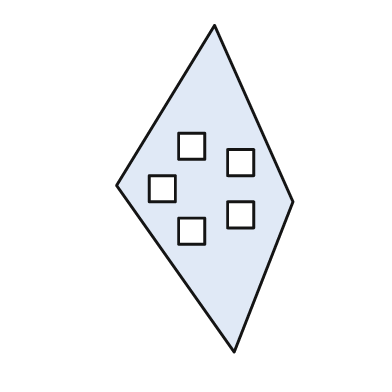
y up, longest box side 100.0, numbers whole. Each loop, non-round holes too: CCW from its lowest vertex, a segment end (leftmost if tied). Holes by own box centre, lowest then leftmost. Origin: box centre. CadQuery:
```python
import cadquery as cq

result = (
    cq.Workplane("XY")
    .moveTo(9.0, -50.0)
    .lineTo(27.0, -4.0)
    .lineTo(3.0, 50.0)
    .lineTo(-27.0, 1.0)
    .close()
    .moveTo(-8.0, -17.0)
    .lineTo(0.0, -17.0)
    .lineTo(0.0, -9.0)
    .lineTo(-8.0, -9.0)
    .close()
    .moveTo(7.0, -12.0)
    .lineTo(15.0, -12.0)
    .lineTo(15.0, -4.0)
    .lineTo(7.0, -4.0)
    .close()
    .moveTo(-17.0, -4.0)
    .lineTo(-9.0, -4.0)
    .lineTo(-9.0, 4.0)
    .lineTo(-17.0, 4.0)
    .close()
    .moveTo(7.0, 4.0)
    .lineTo(15.0, 4.0)
    .lineTo(15.0, 12.0)
    .lineTo(7.0, 12.0)
    .close()
    .moveTo(-8.0, 9.0)
    .lineTo(0.0, 9.0)
    .lineTo(0.0, 17.0)
    .lineTo(-8.0, 17.0)
    .close()
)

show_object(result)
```